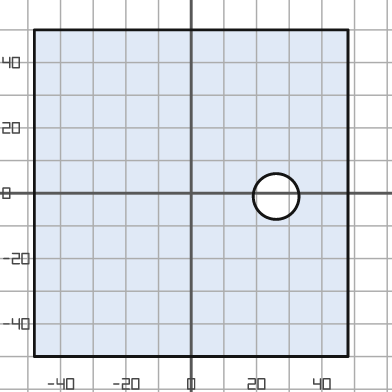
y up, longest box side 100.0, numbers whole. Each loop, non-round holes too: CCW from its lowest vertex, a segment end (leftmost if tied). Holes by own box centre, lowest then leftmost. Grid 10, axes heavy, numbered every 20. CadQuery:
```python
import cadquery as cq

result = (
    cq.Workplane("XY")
    .moveTo(-48.0, -50.0)
    .lineTo(48.0, -50.0)
    .lineTo(48.0, 50.0)
    .lineTo(-48.0, 50.0)
    .close()
    .moveTo(26.0, -1.0)
    .circle(7.0)
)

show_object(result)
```